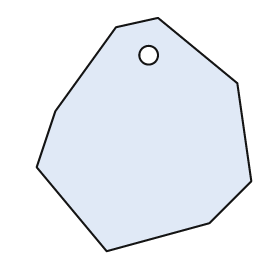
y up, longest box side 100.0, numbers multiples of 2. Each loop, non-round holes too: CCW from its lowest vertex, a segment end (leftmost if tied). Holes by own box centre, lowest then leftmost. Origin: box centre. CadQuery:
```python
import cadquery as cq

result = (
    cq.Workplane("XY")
    .moveTo(-16.0, -50.0)
    .lineTo(28.0, -38.0)
    .lineTo(46.0, -20.0)
    .lineTo(40.0, 22.0)
    .lineTo(6.0, 50.0)
    .lineTo(-12.0, 46.0)
    .lineTo(-38.0, 10.0)
    .lineTo(-46.0, -14.0)
    .close()
    .moveTo(2.0, 34.0)
    .circle(4.0)
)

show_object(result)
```